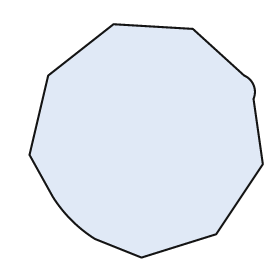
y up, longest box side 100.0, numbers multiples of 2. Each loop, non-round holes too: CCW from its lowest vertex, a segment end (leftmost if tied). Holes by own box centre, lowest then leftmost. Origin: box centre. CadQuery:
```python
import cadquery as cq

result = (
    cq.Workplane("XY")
    .moveTo(-2.0, -50.0)
    .lineTo(30.0, -40.0)
    .lineTo(50.0, -10.0)
    .lineTo(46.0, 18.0)
    .threePointArc((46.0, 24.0), (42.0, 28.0))
    .lineTo(20.0, 48.0)
    .lineTo(-14.0, 50.0)
    .lineTo(-42.0, 28.0)
    .lineTo(-50.0, -6.0)
    .lineTo(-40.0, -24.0)
    .threePointArc((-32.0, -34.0), (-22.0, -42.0))
    .close()
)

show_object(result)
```